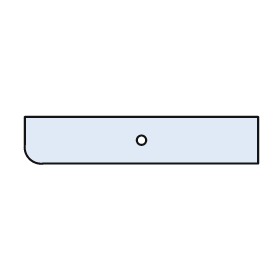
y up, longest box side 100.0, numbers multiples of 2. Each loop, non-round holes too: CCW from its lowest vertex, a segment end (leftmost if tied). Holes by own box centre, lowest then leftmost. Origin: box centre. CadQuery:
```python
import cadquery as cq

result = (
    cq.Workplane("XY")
    .moveTo(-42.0, -10.0)
    .lineTo(50.0, -10.0)
    .lineTo(50.0, 10.0)
    .lineTo(-50.0, 10.0)
    .lineTo(-50.0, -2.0)
    .threePointArc((-48.0, -8.0), (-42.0, -10.0))
    .close()
    .moveTo(0.0, 0.0)
    .circle(2.0)
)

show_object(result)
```